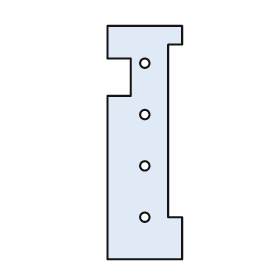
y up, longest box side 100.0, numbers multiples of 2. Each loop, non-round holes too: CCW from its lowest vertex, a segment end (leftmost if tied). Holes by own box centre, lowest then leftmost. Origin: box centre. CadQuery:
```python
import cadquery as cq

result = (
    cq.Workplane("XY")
    .moveTo(-16.0, -50.0)
    .lineTo(16.0, -50.0)
    .lineTo(16.0, -32.0)
    .lineTo(10.0, -32.0)
    .lineTo(10.0, 42.0)
    .lineTo(16.0, 42.0)
    .lineTo(16.0, 50.0)
    .lineTo(-16.0, 50.0)
    .lineTo(-16.0, 36.0)
    .lineTo(-6.0, 36.0)
    .lineTo(-6.0, 20.0)
    .lineTo(-16.0, 20.0)
    .close()
    .moveTo(0.0, -32.0)
    .circle(2.0)
    .moveTo(0.0, -10.0)
    .circle(2.0)
    .moveTo(0.0, 12.0)
    .circle(2.0)
    .moveTo(0.0, 34.0)
    .circle(2.0)
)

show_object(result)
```